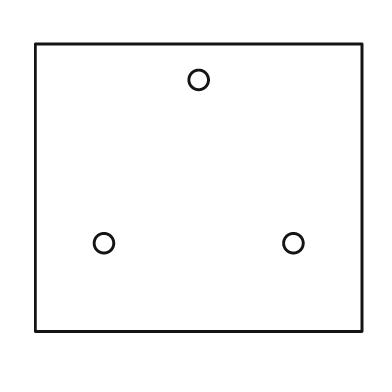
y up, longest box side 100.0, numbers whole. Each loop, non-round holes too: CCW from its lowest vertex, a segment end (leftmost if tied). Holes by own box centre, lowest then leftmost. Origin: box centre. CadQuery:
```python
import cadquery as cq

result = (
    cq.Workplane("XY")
    .moveTo(-50.0, -44.0)
    .lineTo(50.0, -44.0)
    .lineTo(50.0, 44.0)
    .lineTo(-50.0, 44.0)
    .close()
    .moveTo(-29.0, -17.0)
    .circle(3.0)
    .moveTo(29.0, -17.0)
    .circle(3.0)
    .moveTo(0.0, 33.0)
    .circle(3.0)
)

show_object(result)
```